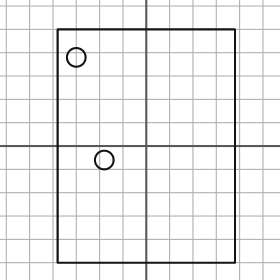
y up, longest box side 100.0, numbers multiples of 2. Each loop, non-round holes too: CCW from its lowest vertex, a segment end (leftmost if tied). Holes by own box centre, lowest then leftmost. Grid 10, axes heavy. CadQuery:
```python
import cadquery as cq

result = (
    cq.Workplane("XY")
    .moveTo(-38.0, -50.0)
    .lineTo(38.0, -50.0)
    .lineTo(38.0, 50.0)
    .lineTo(-38.0, 50.0)
    .close()
    .moveTo(-18.0, -6.0)
    .circle(4.0)
    .moveTo(-30.0, 38.0)
    .circle(4.0)
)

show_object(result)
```